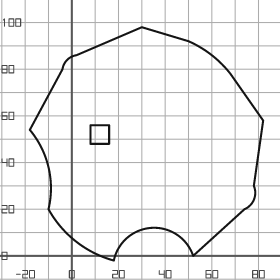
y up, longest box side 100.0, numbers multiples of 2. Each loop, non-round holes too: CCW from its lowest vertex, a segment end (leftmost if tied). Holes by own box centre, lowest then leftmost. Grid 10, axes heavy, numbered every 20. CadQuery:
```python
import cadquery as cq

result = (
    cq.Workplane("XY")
    .moveTo(18.0, -2.0)
    .threePointArc((34.0, 12.0), (52.0, 0.0))
    .lineTo(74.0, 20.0)
    .threePointArc((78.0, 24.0), (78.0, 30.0))
    .lineTo(82.0, 58.0)
    .lineTo(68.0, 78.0)
    .threePointArc((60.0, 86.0), (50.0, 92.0))
    .lineTo(30.0, 98.0)
    .lineTo(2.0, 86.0)
    .threePointArc((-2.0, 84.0), (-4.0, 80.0))
    .lineTo(-18.0, 54.0)
    .threePointArc((-10.0, 38.0), (-10.0, 20.0))
    .threePointArc((2.0, 6.0), (18.0, -2.0))
    .close()
    .moveTo(8.0, 48.0)
    .lineTo(16.0, 48.0)
    .lineTo(16.0, 56.0)
    .lineTo(8.0, 56.0)
    .close()
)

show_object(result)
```